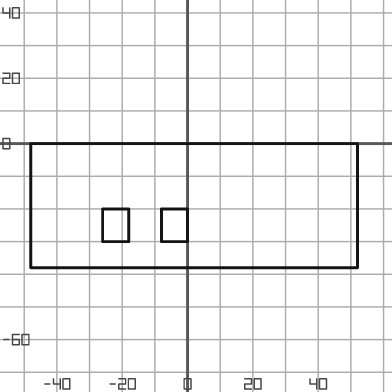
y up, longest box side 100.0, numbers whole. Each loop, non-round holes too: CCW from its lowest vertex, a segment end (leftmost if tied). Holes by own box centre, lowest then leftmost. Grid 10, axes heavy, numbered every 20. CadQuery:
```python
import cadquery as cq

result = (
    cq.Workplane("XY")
    .moveTo(-48.0, -38.0)
    .lineTo(52.0, -38.0)
    .lineTo(52.0, 0.0)
    .lineTo(-48.0, 0.0)
    .close()
    .moveTo(-26.0, -30.0)
    .lineTo(-18.0, -30.0)
    .lineTo(-18.0, -20.0)
    .lineTo(-26.0, -20.0)
    .close()
    .moveTo(-8.0, -30.0)
    .lineTo(0.0, -30.0)
    .lineTo(0.0, -20.0)
    .lineTo(-8.0, -20.0)
    .close()
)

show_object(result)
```